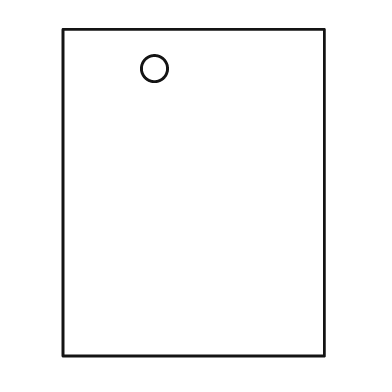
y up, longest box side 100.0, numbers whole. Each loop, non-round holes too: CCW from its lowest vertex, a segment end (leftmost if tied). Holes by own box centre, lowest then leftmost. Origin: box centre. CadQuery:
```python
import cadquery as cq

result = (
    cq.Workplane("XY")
    .moveTo(-40.0, -50.0)
    .lineTo(40.0, -50.0)
    .lineTo(40.0, 50.0)
    .lineTo(-40.0, 50.0)
    .close()
    .moveTo(-12.0, 38.0)
    .circle(4.0)
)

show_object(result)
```